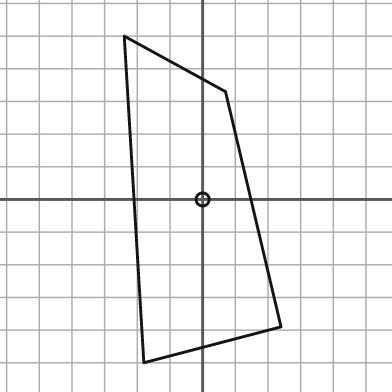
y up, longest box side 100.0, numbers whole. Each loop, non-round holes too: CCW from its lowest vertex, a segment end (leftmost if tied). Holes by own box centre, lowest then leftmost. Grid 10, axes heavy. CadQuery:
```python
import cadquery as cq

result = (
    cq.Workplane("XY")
    .moveTo(-18.0, -50.0)
    .lineTo(24.0, -39.0)
    .lineTo(7.0, 33.0)
    .lineTo(-24.0, 50.0)
    .close()
    .moveTo(0.0, 0.0)
    .circle(2.0)
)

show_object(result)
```